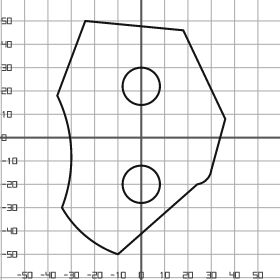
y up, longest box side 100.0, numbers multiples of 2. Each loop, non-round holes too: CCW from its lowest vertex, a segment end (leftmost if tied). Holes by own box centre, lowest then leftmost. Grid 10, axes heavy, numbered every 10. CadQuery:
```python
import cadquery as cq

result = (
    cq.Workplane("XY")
    .moveTo(-10.0, -50.0)
    .lineTo(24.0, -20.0)
    .threePointArc((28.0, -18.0), (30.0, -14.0))
    .lineTo(36.0, 8.0)
    .lineTo(18.0, 46.0)
    .lineTo(-24.0, 50.0)
    .lineTo(-36.0, 18.0)
    .threePointArc((-30.0, -6.0), (-34.0, -30.0))
    .threePointArc((-24.0, -42.0), (-10.0, -50.0))
    .close()
    .moveTo(0.0, -20.0)
    .circle(8.0)
    .moveTo(0.0, 22.0)
    .circle(8.0)
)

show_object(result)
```